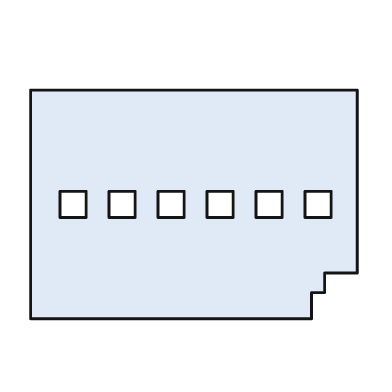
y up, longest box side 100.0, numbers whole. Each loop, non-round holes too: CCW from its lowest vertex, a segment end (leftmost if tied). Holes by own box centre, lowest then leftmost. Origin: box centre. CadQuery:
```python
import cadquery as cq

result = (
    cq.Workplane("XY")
    .moveTo(-50.0, -35.0)
    .lineTo(36.0, -35.0)
    .lineTo(36.0, -27.0)
    .lineTo(40.0, -27.0)
    .lineTo(40.0, -21.0)
    .lineTo(50.0, -21.0)
    .lineTo(50.0, 35.0)
    .lineTo(-50.0, 35.0)
    .close()
    .moveTo(-41.0, -4.0)
    .lineTo(-33.0, -4.0)
    .lineTo(-33.0, 4.0)
    .lineTo(-41.0, 4.0)
    .close()
    .moveTo(-26.0, -4.0)
    .lineTo(-18.0, -4.0)
    .lineTo(-18.0, 4.0)
    .lineTo(-26.0, 4.0)
    .close()
    .moveTo(-11.0, -4.0)
    .lineTo(-3.0, -4.0)
    .lineTo(-3.0, 4.0)
    .lineTo(-11.0, 4.0)
    .close()
    .moveTo(4.0, -4.0)
    .lineTo(12.0, -4.0)
    .lineTo(12.0, 4.0)
    .lineTo(4.0, 4.0)
    .close()
    .moveTo(19.0, -4.0)
    .lineTo(27.0, -4.0)
    .lineTo(27.0, 4.0)
    .lineTo(19.0, 4.0)
    .close()
    .moveTo(34.0, -4.0)
    .lineTo(42.0, -4.0)
    .lineTo(42.0, 4.0)
    .lineTo(34.0, 4.0)
    .close()
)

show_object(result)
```